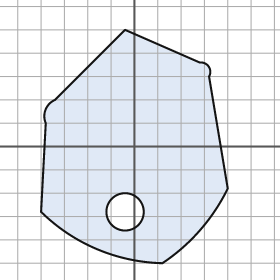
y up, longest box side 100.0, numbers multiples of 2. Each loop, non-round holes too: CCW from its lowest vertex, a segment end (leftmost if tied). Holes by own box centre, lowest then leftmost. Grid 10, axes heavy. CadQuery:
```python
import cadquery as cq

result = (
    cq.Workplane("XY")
    .moveTo(12.0, -50.0)
    .threePointArc((28.0, -36.0), (40.0, -18.0))
    .lineTo(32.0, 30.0)
    .threePointArc((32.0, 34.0), (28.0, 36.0))
    .lineTo(-4.0, 50.0)
    .lineTo(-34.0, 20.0)
    .threePointArc((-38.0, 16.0), (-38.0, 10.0))
    .lineTo(-40.0, -28.0)
    .threePointArc((-16.0, -44.0), (12.0, -50.0))
    .close()
    .moveTo(-4.0, -28.0)
    .circle(8.0)
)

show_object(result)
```